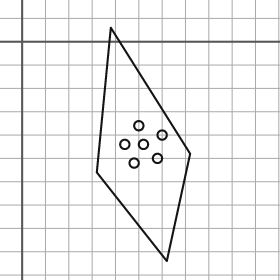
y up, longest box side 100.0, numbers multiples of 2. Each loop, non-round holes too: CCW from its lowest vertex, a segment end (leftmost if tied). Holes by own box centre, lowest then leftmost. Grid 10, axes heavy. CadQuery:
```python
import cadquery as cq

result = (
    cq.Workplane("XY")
    .moveTo(62.0, -94.0)
    .lineTo(72.0, -48.0)
    .lineTo(38.0, 6.0)
    .lineTo(32.0, -56.0)
    .close()
    .moveTo(48.0, -52.0)
    .circle(2.0)
    .moveTo(58.0, -50.0)
    .circle(2.0)
    .moveTo(44.0, -44.0)
    .circle(2.0)
    .moveTo(52.0, -44.0)
    .circle(2.0)
    .moveTo(60.0, -40.0)
    .circle(2.0)
    .moveTo(50.0, -36.0)
    .circle(2.0)
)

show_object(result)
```